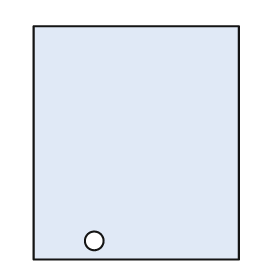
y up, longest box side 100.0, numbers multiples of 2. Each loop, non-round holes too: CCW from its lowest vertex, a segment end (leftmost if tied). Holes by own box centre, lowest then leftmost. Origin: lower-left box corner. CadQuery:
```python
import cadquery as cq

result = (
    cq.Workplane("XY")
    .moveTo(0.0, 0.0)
    .lineTo(88.0, 0.0)
    .lineTo(88.0, 100.0)
    .lineTo(0.0, 100.0)
    .close()
    .moveTo(26.0, 8.0)
    .circle(4.0)
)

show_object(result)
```